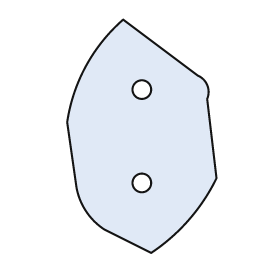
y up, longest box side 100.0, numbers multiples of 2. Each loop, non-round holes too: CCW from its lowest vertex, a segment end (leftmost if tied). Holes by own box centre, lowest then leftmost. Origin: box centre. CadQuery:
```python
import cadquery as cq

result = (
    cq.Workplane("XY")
    .moveTo(4.0, -50.0)
    .threePointArc((20.0, -36.0), (32.0, -18.0))
    .lineTo(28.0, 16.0)
    .threePointArc((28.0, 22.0), (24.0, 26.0))
    .lineTo(-8.0, 50.0)
    .threePointArc((-24.0, 30.0), (-32.0, 6.0))
    .lineTo(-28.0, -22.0)
    .threePointArc((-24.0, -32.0), (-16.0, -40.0))
    .close()
    .moveTo(0.0, -20.0)
    .circle(4.0)
    .moveTo(0.0, 20.0)
    .circle(4.0)
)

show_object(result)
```